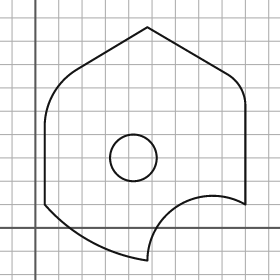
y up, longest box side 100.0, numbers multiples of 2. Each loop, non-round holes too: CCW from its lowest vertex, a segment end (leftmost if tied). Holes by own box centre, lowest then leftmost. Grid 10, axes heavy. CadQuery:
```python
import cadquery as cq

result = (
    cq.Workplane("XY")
    .moveTo(48.0, -14.0)
    .threePointArc((62.0, 10.0), (90.0, 10.0))
    .lineTo(90.0, 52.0)
    .threePointArc((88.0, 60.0), (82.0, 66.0))
    .lineTo(48.0, 86.0)
    .lineTo(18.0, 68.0)
    .threePointArc((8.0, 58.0), (4.0, 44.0))
    .lineTo(4.0, 10.0)
    .threePointArc((24.0, -6.0), (48.0, -14.0))
    .close()
    .moveTo(42.0, 30.0)
    .circle(10.0)
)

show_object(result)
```